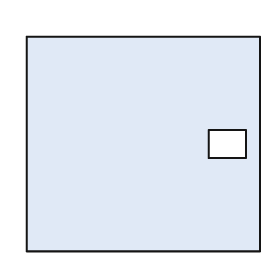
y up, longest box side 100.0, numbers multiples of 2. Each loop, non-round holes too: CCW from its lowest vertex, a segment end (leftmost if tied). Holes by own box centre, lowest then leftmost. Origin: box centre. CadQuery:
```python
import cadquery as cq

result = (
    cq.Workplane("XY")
    .moveTo(-50.0, -46.0)
    .lineTo(50.0, -46.0)
    .lineTo(50.0, 46.0)
    .lineTo(-50.0, 46.0)
    .close()
    .moveTo(28.0, -6.0)
    .lineTo(44.0, -6.0)
    .lineTo(44.0, 6.0)
    .lineTo(28.0, 6.0)
    .close()
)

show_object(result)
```